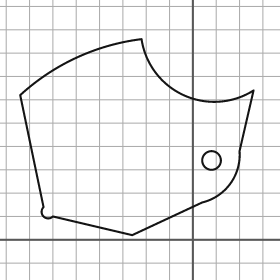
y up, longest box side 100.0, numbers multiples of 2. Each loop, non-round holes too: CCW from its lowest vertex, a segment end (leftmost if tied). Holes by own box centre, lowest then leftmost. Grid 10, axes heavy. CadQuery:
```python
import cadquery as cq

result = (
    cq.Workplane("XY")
    .moveTo(-26.0, 2.0)
    .lineTo(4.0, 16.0)
    .threePointArc((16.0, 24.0), (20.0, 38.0))
    .lineTo(26.0, 64.0)
    .threePointArc((-4.0, 62.0), (-22.0, 86.0))
    .threePointArc((-50.0, 78.0), (-74.0, 62.0))
    .lineTo(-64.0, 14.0)
    .threePointArc((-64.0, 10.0), (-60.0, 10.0))
    .close()
    .moveTo(8.0, 34.0)
    .circle(4.0)
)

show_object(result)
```